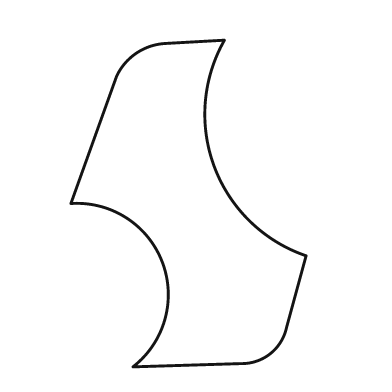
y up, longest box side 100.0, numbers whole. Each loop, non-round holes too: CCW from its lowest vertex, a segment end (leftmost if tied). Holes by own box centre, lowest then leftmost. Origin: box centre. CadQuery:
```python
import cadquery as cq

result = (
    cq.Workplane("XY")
    .moveTo(-17.0, -50.0)
    .lineTo(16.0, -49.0)
    .threePointArc((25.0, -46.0), (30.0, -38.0))
    .lineTo(36.0, -16.0)
    .threePointArc((8.0, 11.0), (11.0, 50.0))
    .lineTo(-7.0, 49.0)
    .threePointArc((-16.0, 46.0), (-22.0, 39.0))
    .lineTo(-36.0, 0.0)
    .threePointArc((-8.0, -18.0), (-17.0, -50.0))
    .close()
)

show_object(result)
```